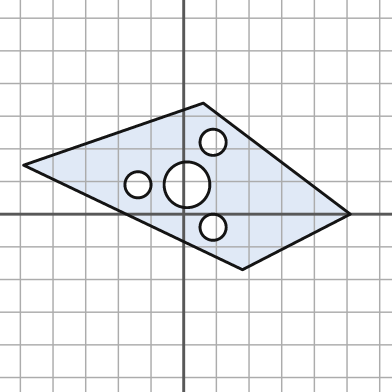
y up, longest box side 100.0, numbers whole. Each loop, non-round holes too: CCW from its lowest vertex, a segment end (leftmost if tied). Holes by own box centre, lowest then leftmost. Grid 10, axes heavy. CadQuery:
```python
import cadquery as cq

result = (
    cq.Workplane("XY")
    .moveTo(18.0, -17.0)
    .lineTo(51.0, 0.0)
    .lineTo(6.0, 34.0)
    .lineTo(-49.0, 15.0)
    .close()
    .moveTo(9.0, -4.0)
    .circle(4.0)
    .moveTo(-14.0, 9.0)
    .circle(4.0)
    .moveTo(1.0, 9.0)
    .circle(7.0)
    .moveTo(9.0, 22.0)
    .circle(4.0)
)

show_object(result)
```